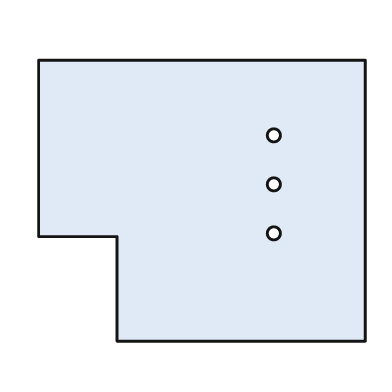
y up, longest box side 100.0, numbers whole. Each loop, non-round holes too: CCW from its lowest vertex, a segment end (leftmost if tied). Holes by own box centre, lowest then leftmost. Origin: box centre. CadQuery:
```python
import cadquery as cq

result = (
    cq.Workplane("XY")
    .moveTo(-26.0, -43.0)
    .lineTo(50.0, -43.0)
    .lineTo(50.0, 43.0)
    .lineTo(-50.0, 43.0)
    .lineTo(-50.0, -11.0)
    .lineTo(-26.0, -11.0)
    .close()
    .moveTo(22.0, -10.0)
    .circle(2.0)
    .moveTo(22.0, 5.0)
    .circle(2.0)
    .moveTo(22.0, 20.0)
    .circle(2.0)
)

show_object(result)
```